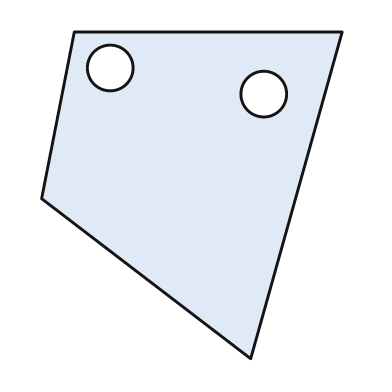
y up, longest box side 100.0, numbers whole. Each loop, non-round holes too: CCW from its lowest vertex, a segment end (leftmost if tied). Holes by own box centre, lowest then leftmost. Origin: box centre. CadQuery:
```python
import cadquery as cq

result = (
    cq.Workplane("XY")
    .moveTo(18.0, -50.0)
    .lineTo(46.0, 50.0)
    .lineTo(-36.0, 50.0)
    .lineTo(-46.0, -1.0)
    .close()
    .moveTo(22.0, 31.0)
    .circle(7.0)
    .moveTo(-25.0, 39.0)
    .circle(7.0)
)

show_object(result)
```